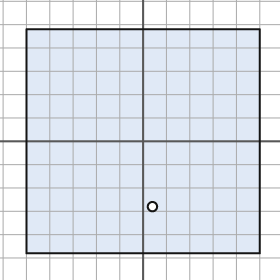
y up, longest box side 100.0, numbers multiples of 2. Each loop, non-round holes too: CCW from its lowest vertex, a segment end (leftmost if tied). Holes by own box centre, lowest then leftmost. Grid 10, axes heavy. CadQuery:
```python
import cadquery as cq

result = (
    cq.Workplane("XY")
    .moveTo(-50.0, -48.0)
    .lineTo(50.0, -48.0)
    .lineTo(50.0, 48.0)
    .lineTo(-50.0, 48.0)
    .close()
    .moveTo(4.0, -28.0)
    .circle(2.0)
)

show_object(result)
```